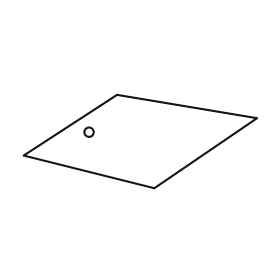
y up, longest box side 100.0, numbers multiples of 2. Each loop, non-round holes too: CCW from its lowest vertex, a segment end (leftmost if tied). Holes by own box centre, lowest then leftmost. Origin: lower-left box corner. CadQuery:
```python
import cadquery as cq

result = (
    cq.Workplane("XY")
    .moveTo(56.0, 0.0)
    .lineTo(100.0, 30.0)
    .lineTo(40.0, 40.0)
    .lineTo(0.0, 14.0)
    .close()
    .moveTo(28.0, 24.0)
    .circle(2.0)
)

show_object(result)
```